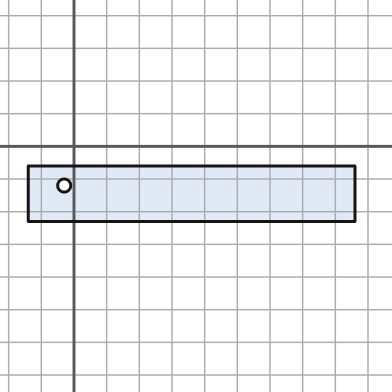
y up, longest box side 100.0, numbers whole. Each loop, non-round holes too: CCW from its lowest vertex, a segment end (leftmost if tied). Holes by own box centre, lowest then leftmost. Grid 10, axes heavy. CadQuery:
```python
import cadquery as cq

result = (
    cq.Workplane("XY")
    .moveTo(-14.0, -23.0)
    .lineTo(86.0, -23.0)
    .lineTo(86.0, -6.0)
    .lineTo(-14.0, -6.0)
    .close()
    .moveTo(-3.0, -12.0)
    .circle(2.0)
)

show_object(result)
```